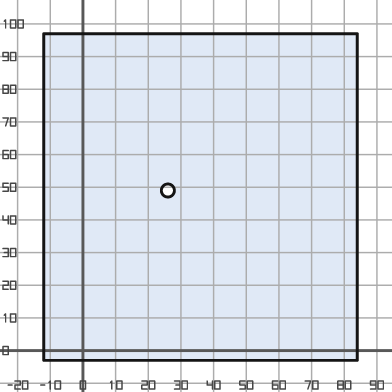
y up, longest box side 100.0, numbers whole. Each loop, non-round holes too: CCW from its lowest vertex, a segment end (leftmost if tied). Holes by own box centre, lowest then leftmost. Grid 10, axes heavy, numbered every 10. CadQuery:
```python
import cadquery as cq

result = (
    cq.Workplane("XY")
    .moveTo(-12.0, -3.0)
    .lineTo(84.0, -3.0)
    .lineTo(84.0, 97.0)
    .lineTo(-12.0, 97.0)
    .close()
    .moveTo(26.0, 49.0)
    .circle(2.0)
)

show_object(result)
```